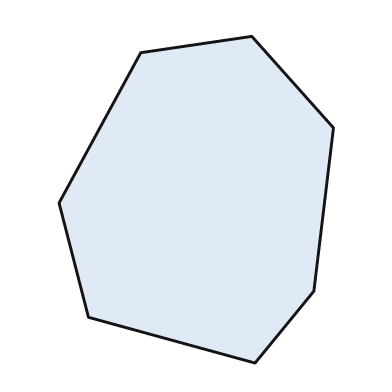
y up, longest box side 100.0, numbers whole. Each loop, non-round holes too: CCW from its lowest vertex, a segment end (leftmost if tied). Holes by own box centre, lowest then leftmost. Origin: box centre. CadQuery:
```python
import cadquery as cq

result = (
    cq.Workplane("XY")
    .moveTo(18.0, -50.0)
    .lineTo(36.0, -28.0)
    .lineTo(42.0, 22.0)
    .lineTo(17.0, 50.0)
    .lineTo(-17.0, 45.0)
    .lineTo(-42.0, -1.0)
    .lineTo(-33.0, -36.0)
    .close()
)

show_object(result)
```